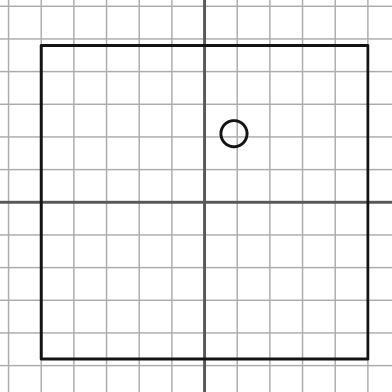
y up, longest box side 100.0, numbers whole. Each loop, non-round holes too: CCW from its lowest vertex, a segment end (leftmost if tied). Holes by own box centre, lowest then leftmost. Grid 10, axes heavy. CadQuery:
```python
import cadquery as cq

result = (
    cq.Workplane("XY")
    .moveTo(-50.0, -48.0)
    .lineTo(50.0, -48.0)
    .lineTo(50.0, 48.0)
    .lineTo(-50.0, 48.0)
    .close()
    .moveTo(9.0, 21.0)
    .circle(4.0)
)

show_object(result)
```